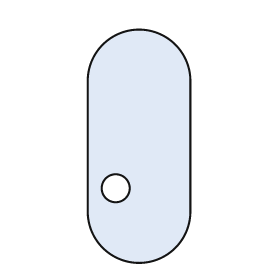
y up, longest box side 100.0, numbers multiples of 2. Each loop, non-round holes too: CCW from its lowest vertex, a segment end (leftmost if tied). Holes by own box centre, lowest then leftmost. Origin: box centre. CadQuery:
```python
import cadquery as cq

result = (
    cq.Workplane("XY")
    .moveTo(-22.0, -28.0)
    .threePointArc((0.0, -50.0), (22.0, -28.0))
    .lineTo(22.0, 28.0)
    .threePointArc((0.0, 50.0), (-22.0, 28.0))
    .close()
    .moveTo(-10.0, -18.0)
    .circle(6.0)
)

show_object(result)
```